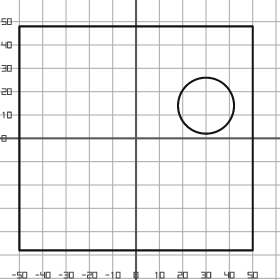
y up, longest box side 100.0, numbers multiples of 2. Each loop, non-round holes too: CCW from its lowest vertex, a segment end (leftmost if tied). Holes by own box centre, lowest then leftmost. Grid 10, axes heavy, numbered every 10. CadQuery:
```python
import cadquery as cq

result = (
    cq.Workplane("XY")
    .moveTo(-50.0, -48.0)
    .lineTo(50.0, -48.0)
    .lineTo(50.0, 48.0)
    .lineTo(-50.0, 48.0)
    .close()
    .moveTo(30.0, 14.0)
    .circle(12.0)
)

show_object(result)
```